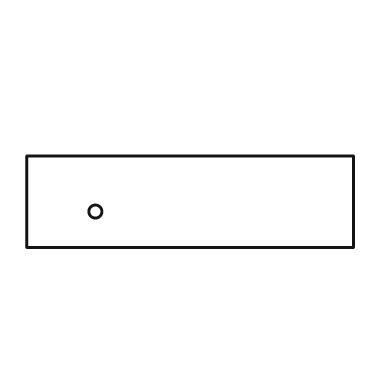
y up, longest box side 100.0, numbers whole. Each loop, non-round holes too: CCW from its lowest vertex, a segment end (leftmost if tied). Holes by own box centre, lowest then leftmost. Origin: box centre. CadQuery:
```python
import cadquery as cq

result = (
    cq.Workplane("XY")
    .moveTo(-50.0, -14.0)
    .lineTo(50.0, -14.0)
    .lineTo(50.0, 14.0)
    .lineTo(-50.0, 14.0)
    .close()
    .moveTo(-29.0, -3.0)
    .circle(2.0)
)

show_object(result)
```